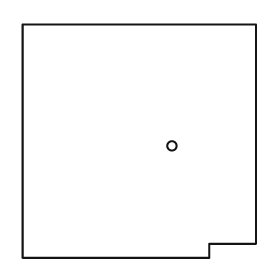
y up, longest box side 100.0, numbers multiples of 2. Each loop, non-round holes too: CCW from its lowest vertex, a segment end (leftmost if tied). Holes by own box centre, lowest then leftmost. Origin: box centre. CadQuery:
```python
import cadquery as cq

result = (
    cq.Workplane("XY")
    .moveTo(-50.0, -50.0)
    .lineTo(30.0, -50.0)
    .lineTo(30.0, -44.0)
    .lineTo(50.0, -44.0)
    .lineTo(50.0, 50.0)
    .lineTo(-50.0, 50.0)
    .close()
    .moveTo(14.0, -2.0)
    .circle(2.0)
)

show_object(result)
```